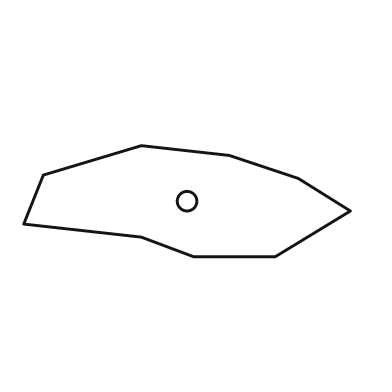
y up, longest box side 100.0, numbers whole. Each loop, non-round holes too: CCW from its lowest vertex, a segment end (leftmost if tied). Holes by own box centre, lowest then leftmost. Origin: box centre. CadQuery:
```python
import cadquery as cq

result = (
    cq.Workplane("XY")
    .moveTo(2.0, -17.0)
    .lineTo(27.0, -17.0)
    .lineTo(50.0, -3.0)
    .lineTo(34.0, 7.0)
    .lineTo(13.0, 14.0)
    .lineTo(-14.0, 17.0)
    .lineTo(-44.0, 8.0)
    .lineTo(-50.0, -7.0)
    .lineTo(-14.0, -11.0)
    .close()
    .moveTo(0.0, 0.0)
    .circle(3.0)
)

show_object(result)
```